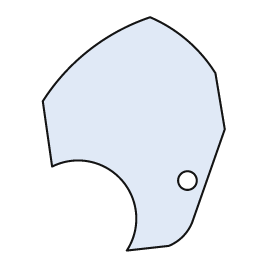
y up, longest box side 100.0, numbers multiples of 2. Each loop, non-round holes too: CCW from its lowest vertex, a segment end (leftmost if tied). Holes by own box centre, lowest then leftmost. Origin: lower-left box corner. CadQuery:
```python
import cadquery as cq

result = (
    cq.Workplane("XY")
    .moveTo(36.0, 0.0)
    .lineTo(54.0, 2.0)
    .threePointArc((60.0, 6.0), (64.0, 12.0))
    .lineTo(78.0, 52.0)
    .lineTo(74.0, 76.0)
    .threePointArc((62.0, 90.0), (46.0, 100.0))
    .threePointArc((20.0, 86.0), (0.0, 64.0))
    .lineTo(4.0, 36.0)
    .threePointArc((34.0, 30.0), (36.0, 0.0))
    .close()
    .moveTo(62.0, 30.0)
    .circle(4.0)
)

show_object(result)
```